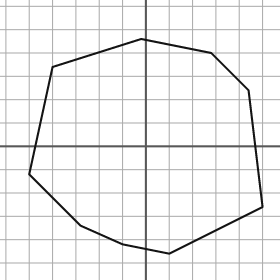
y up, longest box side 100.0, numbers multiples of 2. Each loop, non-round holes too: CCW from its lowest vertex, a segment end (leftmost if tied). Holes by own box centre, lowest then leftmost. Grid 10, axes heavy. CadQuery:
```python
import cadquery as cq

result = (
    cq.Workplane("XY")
    .moveTo(10.0, -46.0)
    .lineTo(50.0, -26.0)
    .lineTo(44.0, 24.0)
    .lineTo(28.0, 40.0)
    .lineTo(-2.0, 46.0)
    .lineTo(-40.0, 34.0)
    .lineTo(-50.0, -12.0)
    .lineTo(-28.0, -34.0)
    .lineTo(-10.0, -42.0)
    .close()
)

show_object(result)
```